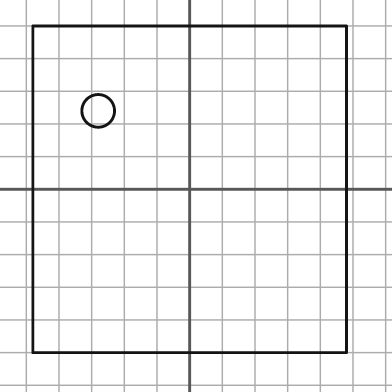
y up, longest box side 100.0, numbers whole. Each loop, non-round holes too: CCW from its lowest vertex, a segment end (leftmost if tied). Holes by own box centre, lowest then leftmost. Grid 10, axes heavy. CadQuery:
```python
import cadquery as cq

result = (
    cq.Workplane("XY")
    .moveTo(-48.0, -50.0)
    .lineTo(48.0, -50.0)
    .lineTo(48.0, 50.0)
    .lineTo(-48.0, 50.0)
    .close()
    .moveTo(-28.0, 24.0)
    .circle(5.0)
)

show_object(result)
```